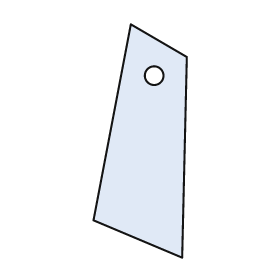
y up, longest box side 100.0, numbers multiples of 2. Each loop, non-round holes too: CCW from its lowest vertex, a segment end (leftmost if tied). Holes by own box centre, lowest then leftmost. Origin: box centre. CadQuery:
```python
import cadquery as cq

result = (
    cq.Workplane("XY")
    .moveTo(18.0, -50.0)
    .lineTo(20.0, 36.0)
    .lineTo(-4.0, 50.0)
    .lineTo(-20.0, -34.0)
    .close()
    .moveTo(6.0, 28.0)
    .circle(4.0)
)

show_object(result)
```